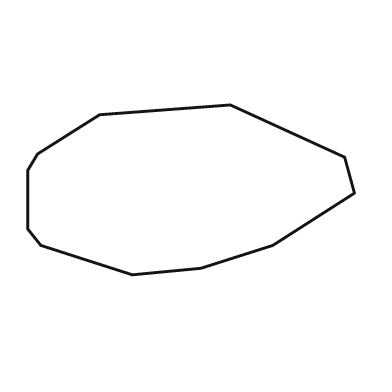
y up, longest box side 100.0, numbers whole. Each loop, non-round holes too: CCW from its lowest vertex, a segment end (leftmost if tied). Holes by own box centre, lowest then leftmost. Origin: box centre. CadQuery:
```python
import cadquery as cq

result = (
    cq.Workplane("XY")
    .moveTo(-18.0, -26.0)
    .lineTo(3.0, -24.0)
    .lineTo(25.0, -17.0)
    .lineTo(50.0, -1.0)
    .lineTo(47.0, 10.0)
    .lineTo(12.0, 26.0)
    .lineTo(-28.0, 23.0)
    .lineTo(-47.0, 11.0)
    .lineTo(-50.0, 6.0)
    .lineTo(-50.0, -12.0)
    .lineTo(-46.0, -17.0)
    .close()
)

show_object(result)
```